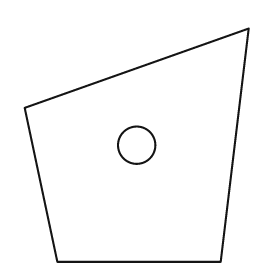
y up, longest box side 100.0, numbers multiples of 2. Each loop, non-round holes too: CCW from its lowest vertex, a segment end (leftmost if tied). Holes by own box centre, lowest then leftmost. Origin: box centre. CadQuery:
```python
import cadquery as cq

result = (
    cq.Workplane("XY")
    .moveTo(-34.0, -50.0)
    .lineTo(36.0, -50.0)
    .lineTo(48.0, 50.0)
    .lineTo(-48.0, 16.0)
    .close()
    .moveTo(0.0, 0.0)
    .circle(8.0)
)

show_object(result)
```